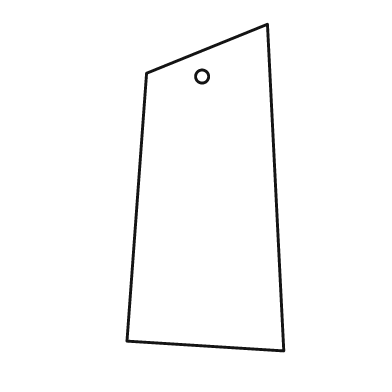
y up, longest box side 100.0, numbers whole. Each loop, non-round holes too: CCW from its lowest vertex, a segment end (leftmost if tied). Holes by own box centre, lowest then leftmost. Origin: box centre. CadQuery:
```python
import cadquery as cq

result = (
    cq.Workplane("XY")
    .moveTo(24.0, -50.0)
    .lineTo(19.0, 50.0)
    .lineTo(-18.0, 35.0)
    .lineTo(-24.0, -47.0)
    .close()
    .moveTo(-1.0, 34.0)
    .circle(2.0)
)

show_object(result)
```